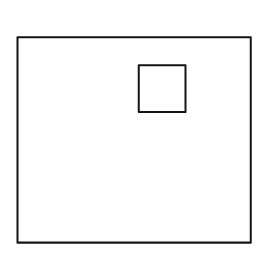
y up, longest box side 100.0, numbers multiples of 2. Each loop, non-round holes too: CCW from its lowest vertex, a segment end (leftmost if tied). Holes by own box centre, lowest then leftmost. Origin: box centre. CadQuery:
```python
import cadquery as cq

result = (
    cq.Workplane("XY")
    .moveTo(-50.0, -44.0)
    .lineTo(50.0, -44.0)
    .lineTo(50.0, 44.0)
    .lineTo(-50.0, 44.0)
    .close()
    .moveTo(2.0, 12.0)
    .lineTo(22.0, 12.0)
    .lineTo(22.0, 32.0)
    .lineTo(2.0, 32.0)
    .close()
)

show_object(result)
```